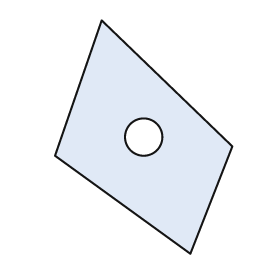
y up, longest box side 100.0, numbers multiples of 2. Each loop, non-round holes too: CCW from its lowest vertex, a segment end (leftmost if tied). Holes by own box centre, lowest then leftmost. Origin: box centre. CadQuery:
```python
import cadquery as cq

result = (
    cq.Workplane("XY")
    .moveTo(20.0, -50.0)
    .lineTo(38.0, -4.0)
    .lineTo(-18.0, 50.0)
    .lineTo(-38.0, -8.0)
    .close()
    .moveTo(0.0, 0.0)
    .circle(8.0)
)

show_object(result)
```